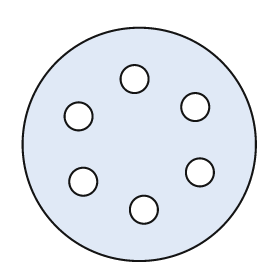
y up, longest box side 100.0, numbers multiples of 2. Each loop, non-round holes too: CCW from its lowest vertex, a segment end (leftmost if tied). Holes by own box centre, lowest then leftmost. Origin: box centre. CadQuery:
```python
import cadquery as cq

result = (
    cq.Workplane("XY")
    .moveTo(0.0, 0.0)
    .circle(50.0)
    .moveTo(2.0, -28.0)
    .circle(6.0)
    .moveTo(-24.0, -16.0)
    .circle(6.0)
    .moveTo(26.0, -12.0)
    .circle(6.0)
    .moveTo(-26.0, 12.0)
    .circle(6.0)
    .moveTo(24.0, 16.0)
    .circle(6.0)
    .moveTo(-2.0, 28.0)
    .circle(6.0)
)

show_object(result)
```